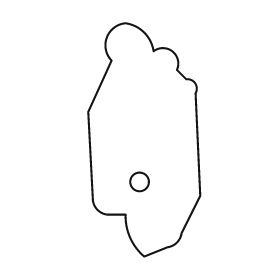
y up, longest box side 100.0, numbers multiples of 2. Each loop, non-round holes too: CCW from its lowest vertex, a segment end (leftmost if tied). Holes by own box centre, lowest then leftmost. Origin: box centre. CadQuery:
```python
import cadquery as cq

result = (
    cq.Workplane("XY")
    .moveTo(0.0, -50.0)
    .lineTo(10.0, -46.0)
    .threePointArc((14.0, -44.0), (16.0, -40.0))
    .lineTo(24.0, -24.0)
    .lineTo(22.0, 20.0)
    .threePointArc((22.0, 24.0), (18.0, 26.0))
    .lineTo(14.0, 30.0)
    .threePointArc((12.0, 38.0), (4.0, 38.0))
    .threePointArc((0.0, 46.0), (-8.0, 50.0))
    .threePointArc((-16.0, 44.0), (-14.0, 34.0))
    .lineTo(-24.0, 12.0)
    .lineTo(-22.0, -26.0)
    .threePointArc((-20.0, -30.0), (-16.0, -32.0))
    .lineTo(-8.0, -32.0)
    .threePointArc((-6.0, -42.0), (0.0, -50.0))
    .close()
    .moveTo(-2.0, -18.0)
    .circle(4.0)
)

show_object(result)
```